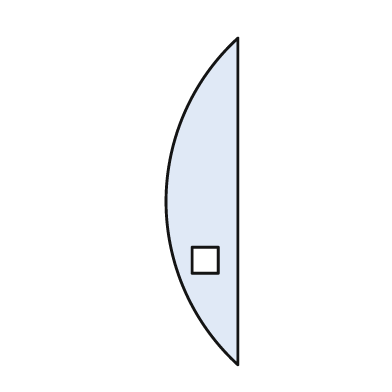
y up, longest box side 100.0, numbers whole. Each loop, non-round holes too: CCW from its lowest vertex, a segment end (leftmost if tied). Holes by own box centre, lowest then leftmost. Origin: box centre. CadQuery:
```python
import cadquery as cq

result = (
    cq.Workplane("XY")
    .moveTo(11.0, -50.0)
    .lineTo(11.0, 50.0)
    .threePointArc((-11.0, 0.0), (11.0, -50.0))
    .close()
    .moveTo(-3.0, -22.0)
    .lineTo(5.0, -22.0)
    .lineTo(5.0, -14.0)
    .lineTo(-3.0, -14.0)
    .close()
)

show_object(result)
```